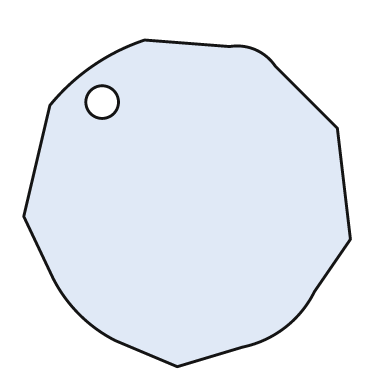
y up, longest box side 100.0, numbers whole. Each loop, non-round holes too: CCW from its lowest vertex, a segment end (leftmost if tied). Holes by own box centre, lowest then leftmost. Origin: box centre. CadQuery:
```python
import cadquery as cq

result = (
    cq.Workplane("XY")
    .moveTo(-3.0, -50.0)
    .lineTo(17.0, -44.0)
    .threePointArc((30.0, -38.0), (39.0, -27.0))
    .lineTo(50.0, -11.0)
    .lineTo(46.0, 23.0)
    .lineTo(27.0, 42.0)
    .threePointArc((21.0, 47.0), (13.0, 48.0))
    .lineTo(-13.0, 50.0)
    .threePointArc((-29.0, 42.0), (-42.0, 30.0))
    .lineTo(-50.0, -4.0)
    .lineTo(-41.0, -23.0)
    .threePointArc((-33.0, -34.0), (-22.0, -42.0))
    .close()
    .moveTo(-26.0, 31.0)
    .circle(5.0)
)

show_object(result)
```